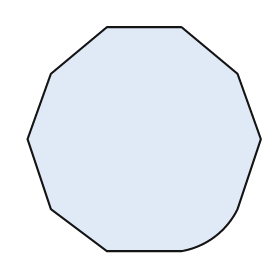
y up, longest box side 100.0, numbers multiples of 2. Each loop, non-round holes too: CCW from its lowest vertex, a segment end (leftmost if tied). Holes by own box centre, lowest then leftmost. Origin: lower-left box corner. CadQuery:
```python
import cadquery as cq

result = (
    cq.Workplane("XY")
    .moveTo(34.0, 0.0)
    .lineTo(66.0, 0.0)
    .threePointArc((80.0, 6.0), (90.0, 18.0))
    .lineTo(100.0, 48.0)
    .lineTo(90.0, 76.0)
    .lineTo(66.0, 96.0)
    .lineTo(34.0, 96.0)
    .lineTo(10.0, 76.0)
    .lineTo(0.0, 48.0)
    .lineTo(10.0, 18.0)
    .close()
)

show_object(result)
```